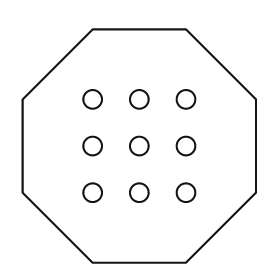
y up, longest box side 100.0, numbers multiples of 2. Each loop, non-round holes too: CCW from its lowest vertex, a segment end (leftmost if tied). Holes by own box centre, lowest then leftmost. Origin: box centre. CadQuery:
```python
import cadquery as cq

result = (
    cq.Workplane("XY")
    .moveTo(-20.0, -50.0)
    .lineTo(20.0, -50.0)
    .lineTo(50.0, -20.0)
    .lineTo(50.0, 20.0)
    .lineTo(20.0, 50.0)
    .lineTo(-20.0, 50.0)
    .lineTo(-50.0, 20.0)
    .lineTo(-50.0, -20.0)
    .close()
    .moveTo(-20.0, -20.0)
    .circle(4.0)
    .moveTo(0.0, -20.0)
    .circle(4.0)
    .moveTo(20.0, -20.0)
    .circle(4.0)
    .moveTo(-20.0, 0.0)
    .circle(4.0)
    .moveTo(0.0, 0.0)
    .circle(4.0)
    .moveTo(20.0, 0.0)
    .circle(4.0)
    .moveTo(-20.0, 20.0)
    .circle(4.0)
    .moveTo(0.0, 20.0)
    .circle(4.0)
    .moveTo(20.0, 20.0)
    .circle(4.0)
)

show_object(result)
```